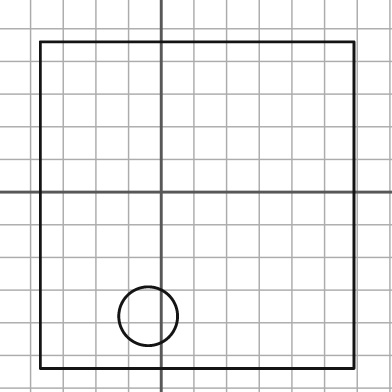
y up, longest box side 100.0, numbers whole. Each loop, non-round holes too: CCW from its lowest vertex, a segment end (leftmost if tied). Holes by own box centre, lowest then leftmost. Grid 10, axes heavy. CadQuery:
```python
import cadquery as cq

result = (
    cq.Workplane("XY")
    .moveTo(-37.0, -54.0)
    .lineTo(59.0, -54.0)
    .lineTo(59.0, 46.0)
    .lineTo(-37.0, 46.0)
    .close()
    .moveTo(-4.0, -38.0)
    .circle(9.0)
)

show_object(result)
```